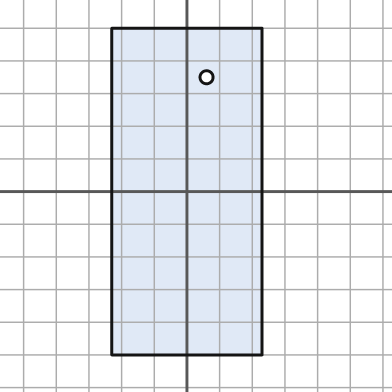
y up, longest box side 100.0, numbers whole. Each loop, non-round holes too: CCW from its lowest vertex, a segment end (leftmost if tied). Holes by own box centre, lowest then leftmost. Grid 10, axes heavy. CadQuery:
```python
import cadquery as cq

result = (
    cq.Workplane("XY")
    .moveTo(-23.0, -50.0)
    .lineTo(23.0, -50.0)
    .lineTo(23.0, 50.0)
    .lineTo(-23.0, 50.0)
    .close()
    .moveTo(6.0, 35.0)
    .circle(2.0)
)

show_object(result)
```